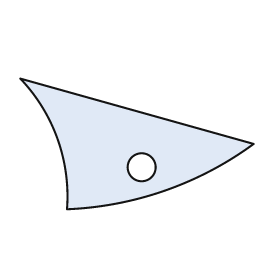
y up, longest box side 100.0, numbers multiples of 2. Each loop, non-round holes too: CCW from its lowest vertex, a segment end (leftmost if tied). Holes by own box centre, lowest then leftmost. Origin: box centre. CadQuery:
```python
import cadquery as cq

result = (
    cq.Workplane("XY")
    .moveTo(-30.0, -28.0)
    .threePointArc((12.0, -20.0), (50.0, 0.0))
    .lineTo(-50.0, 28.0)
    .threePointArc((-34.0, 2.0), (-30.0, -28.0))
    .close()
    .moveTo(2.0, -10.0)
    .circle(6.0)
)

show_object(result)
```